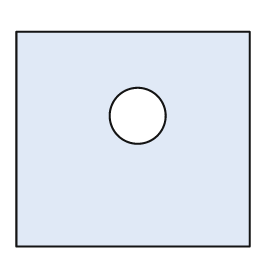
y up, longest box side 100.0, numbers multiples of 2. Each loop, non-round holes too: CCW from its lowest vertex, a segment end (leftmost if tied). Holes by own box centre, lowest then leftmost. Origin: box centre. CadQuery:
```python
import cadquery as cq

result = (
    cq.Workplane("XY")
    .moveTo(-50.0, -46.0)
    .lineTo(50.0, -46.0)
    .lineTo(50.0, 46.0)
    .lineTo(-50.0, 46.0)
    .close()
    .moveTo(2.0, 10.0)
    .circle(12.0)
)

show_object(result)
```